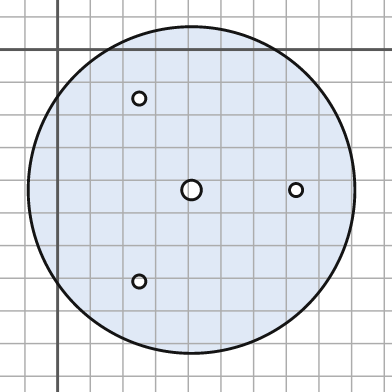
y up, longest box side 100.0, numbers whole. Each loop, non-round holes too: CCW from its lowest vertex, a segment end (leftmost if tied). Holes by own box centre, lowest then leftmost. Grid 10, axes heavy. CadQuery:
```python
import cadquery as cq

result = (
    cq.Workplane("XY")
    .moveTo(41.0, -43.0)
    .circle(50.0)
    .moveTo(25.0, -71.0)
    .circle(2.0)
    .moveTo(41.0, -43.0)
    .circle(3.0)
    .moveTo(73.0, -43.0)
    .circle(2.0)
    .moveTo(25.0, -15.0)
    .circle(2.0)
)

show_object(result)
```